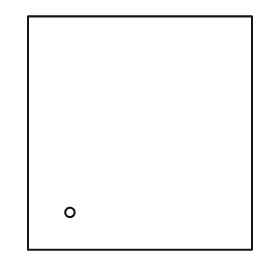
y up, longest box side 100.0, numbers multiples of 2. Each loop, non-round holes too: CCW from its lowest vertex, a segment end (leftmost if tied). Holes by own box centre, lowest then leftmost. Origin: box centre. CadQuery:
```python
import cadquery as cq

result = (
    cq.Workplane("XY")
    .moveTo(-48.0, -50.0)
    .lineTo(48.0, -50.0)
    .lineTo(48.0, 50.0)
    .lineTo(-48.0, 50.0)
    .close()
    .moveTo(-30.0, -34.0)
    .circle(2.0)
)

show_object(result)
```